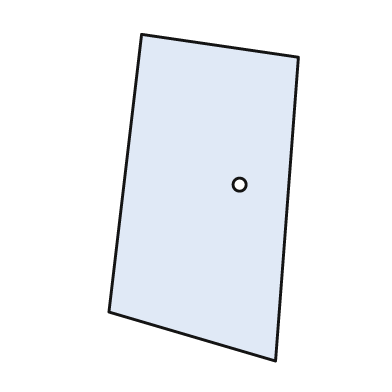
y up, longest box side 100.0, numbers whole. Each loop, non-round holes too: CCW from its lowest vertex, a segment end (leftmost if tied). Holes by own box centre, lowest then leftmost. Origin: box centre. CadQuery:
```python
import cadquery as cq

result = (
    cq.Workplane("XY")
    .moveTo(22.0, -50.0)
    .lineTo(29.0, 43.0)
    .lineTo(-19.0, 50.0)
    .lineTo(-29.0, -35.0)
    .close()
    .moveTo(11.0, 4.0)
    .circle(2.0)
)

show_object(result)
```